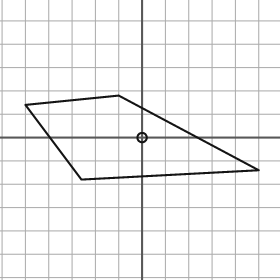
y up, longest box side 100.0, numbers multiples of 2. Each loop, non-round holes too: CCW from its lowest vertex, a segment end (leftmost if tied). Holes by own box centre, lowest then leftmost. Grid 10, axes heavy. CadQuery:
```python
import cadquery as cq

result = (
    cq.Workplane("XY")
    .moveTo(-26.0, -18.0)
    .lineTo(50.0, -14.0)
    .lineTo(-10.0, 18.0)
    .lineTo(-50.0, 14.0)
    .close()
    .moveTo(0.0, 0.0)
    .circle(2.0)
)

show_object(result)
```